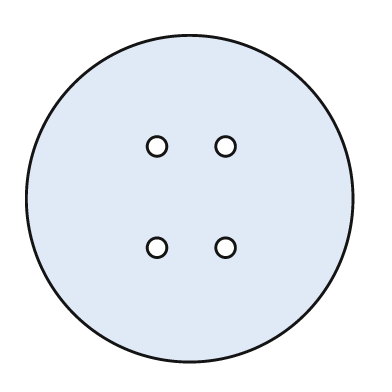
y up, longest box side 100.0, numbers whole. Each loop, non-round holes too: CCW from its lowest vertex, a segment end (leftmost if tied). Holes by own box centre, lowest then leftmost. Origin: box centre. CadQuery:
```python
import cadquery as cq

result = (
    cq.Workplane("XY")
    .moveTo(0.0, 0.0)
    .circle(50.0)
    .moveTo(-10.0, -15.0)
    .circle(3.0)
    .moveTo(11.0, -15.0)
    .circle(3.0)
    .moveTo(-10.0, 16.0)
    .circle(3.0)
    .moveTo(11.0, 16.0)
    .circle(3.0)
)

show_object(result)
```